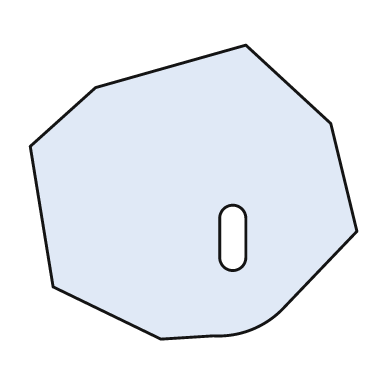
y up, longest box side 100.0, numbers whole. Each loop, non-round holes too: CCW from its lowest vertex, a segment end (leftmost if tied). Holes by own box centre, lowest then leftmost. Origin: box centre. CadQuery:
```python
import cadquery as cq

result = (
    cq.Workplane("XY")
    .moveTo(-10.0, -45.0)
    .lineTo(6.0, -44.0)
    .threePointArc((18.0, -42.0), (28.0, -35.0))
    .lineTo(50.0, -12.0)
    .lineTo(42.0, 21.0)
    .lineTo(16.0, 45.0)
    .lineTo(-30.0, 32.0)
    .lineTo(-50.0, 14.0)
    .lineTo(-43.0, -29.0)
    .close()
    .moveTo(8.0, -20.0)
    .threePointArc((12.0, -24.0), (16.0, -20.0))
    .lineTo(16.0, -8.0)
    .threePointArc((12.0, -4.0), (8.0, -8.0))
    .close()
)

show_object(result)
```